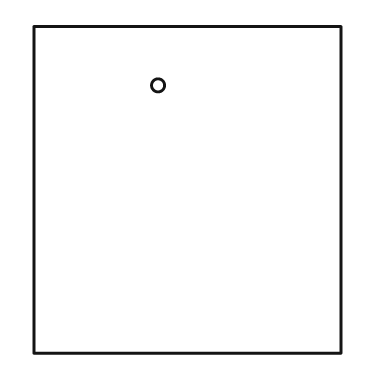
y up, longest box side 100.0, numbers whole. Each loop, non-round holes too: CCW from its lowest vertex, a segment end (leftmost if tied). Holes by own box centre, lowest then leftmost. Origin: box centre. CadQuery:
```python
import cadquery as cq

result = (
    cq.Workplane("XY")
    .moveTo(-47.0, -50.0)
    .lineTo(47.0, -50.0)
    .lineTo(47.0, 50.0)
    .lineTo(-47.0, 50.0)
    .close()
    .moveTo(-9.0, 32.0)
    .circle(2.0)
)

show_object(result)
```